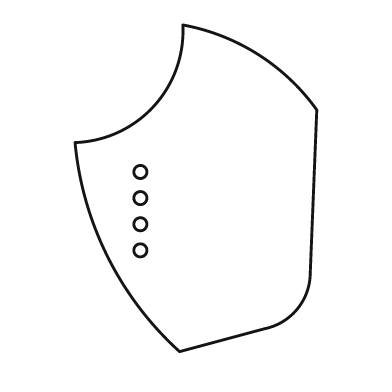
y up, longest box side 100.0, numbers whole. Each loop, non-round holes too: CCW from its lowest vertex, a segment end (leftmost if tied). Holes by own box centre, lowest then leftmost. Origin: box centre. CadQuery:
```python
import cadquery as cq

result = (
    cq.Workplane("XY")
    .moveTo(-5.0, -50.0)
    .lineTo(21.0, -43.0)
    .threePointArc((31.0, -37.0), (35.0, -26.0))
    .lineTo(37.0, 24.0)
    .threePointArc((19.0, 41.0), (-4.0, 50.0))
    .threePointArc((-13.0, 25.0), (-37.0, 14.0))
    .threePointArc((-27.0, -21.0), (-5.0, -50.0))
    .close()
    .moveTo(-17.0, -19.0)
    .circle(2.0)
    .moveTo(-17.0, -11.0)
    .circle(2.0)
    .moveTo(-17.0, -3.0)
    .circle(2.0)
    .moveTo(-17.0, 5.0)
    .circle(2.0)
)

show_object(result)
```